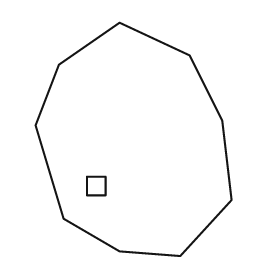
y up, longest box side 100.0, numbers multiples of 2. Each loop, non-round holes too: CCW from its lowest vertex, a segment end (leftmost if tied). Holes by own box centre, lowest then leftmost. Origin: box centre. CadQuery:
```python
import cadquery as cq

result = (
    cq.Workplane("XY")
    .moveTo(20.0, -50.0)
    .lineTo(42.0, -26.0)
    .lineTo(38.0, 8.0)
    .lineTo(24.0, 36.0)
    .lineTo(-6.0, 50.0)
    .lineTo(-32.0, 32.0)
    .lineTo(-42.0, 6.0)
    .lineTo(-30.0, -34.0)
    .lineTo(-6.0, -48.0)
    .close()
    .moveTo(-20.0, -24.0)
    .lineTo(-12.0, -24.0)
    .lineTo(-12.0, -16.0)
    .lineTo(-20.0, -16.0)
    .close()
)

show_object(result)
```